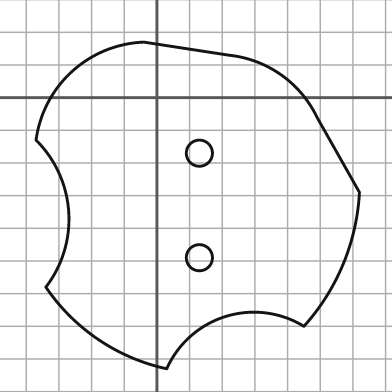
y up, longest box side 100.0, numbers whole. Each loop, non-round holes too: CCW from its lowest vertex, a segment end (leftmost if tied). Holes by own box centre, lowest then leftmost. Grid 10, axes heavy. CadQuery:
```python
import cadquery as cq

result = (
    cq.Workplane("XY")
    .moveTo(3.0, -83.0)
    .threePointArc((21.0, -67.0), (45.0, -70.0))
    .threePointArc((57.0, -51.0), (62.0, -29.0))
    .lineTo(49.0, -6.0)
    .threePointArc((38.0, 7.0), (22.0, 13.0))
    .lineTo(-4.0, 17.0)
    .threePointArc((-26.0, 8.0), (-37.0, -13.0))
    .threePointArc((-27.0, -35.0), (-34.0, -58.0))
    .threePointArc((-18.0, -74.0), (3.0, -83.0))
    .close()
    .moveTo(13.0, -49.0)
    .circle(4.0)
    .moveTo(13.0, -17.0)
    .circle(4.0)
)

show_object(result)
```